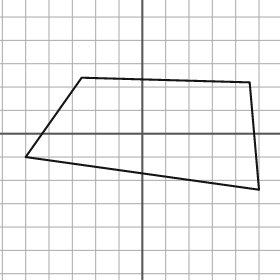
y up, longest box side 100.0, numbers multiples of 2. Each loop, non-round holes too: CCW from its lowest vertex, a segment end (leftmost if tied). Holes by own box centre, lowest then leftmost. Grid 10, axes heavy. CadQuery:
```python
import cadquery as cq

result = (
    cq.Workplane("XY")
    .moveTo(50.0, -24.0)
    .lineTo(46.0, 22.0)
    .lineTo(-26.0, 24.0)
    .lineTo(-50.0, -10.0)
    .close()
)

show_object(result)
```